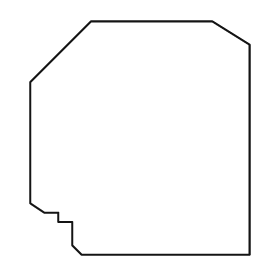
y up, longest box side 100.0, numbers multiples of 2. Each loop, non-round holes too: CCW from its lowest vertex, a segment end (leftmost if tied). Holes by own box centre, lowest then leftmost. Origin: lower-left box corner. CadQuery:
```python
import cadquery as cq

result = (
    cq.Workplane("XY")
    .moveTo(22.0, 0.0)
    .lineTo(94.0, 0.0)
    .lineTo(94.0, 90.0)
    .lineTo(78.0, 100.0)
    .lineTo(26.0, 100.0)
    .lineTo(0.0, 74.0)
    .lineTo(0.0, 22.0)
    .lineTo(6.0, 18.0)
    .lineTo(12.0, 18.0)
    .lineTo(12.0, 14.0)
    .lineTo(18.0, 14.0)
    .lineTo(18.0, 4.0)
    .close()
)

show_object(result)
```